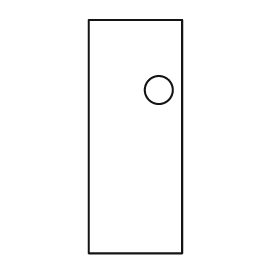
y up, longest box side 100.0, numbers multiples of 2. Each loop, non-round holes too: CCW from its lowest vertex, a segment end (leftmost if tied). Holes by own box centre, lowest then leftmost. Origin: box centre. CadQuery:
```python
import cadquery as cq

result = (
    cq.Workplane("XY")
    .moveTo(-20.0, -50.0)
    .lineTo(20.0, -50.0)
    .lineTo(20.0, 50.0)
    .lineTo(-20.0, 50.0)
    .close()
    .moveTo(10.0, 20.0)
    .circle(6.0)
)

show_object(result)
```